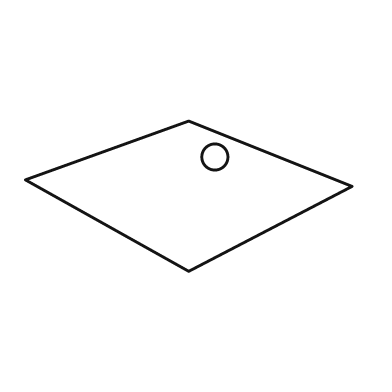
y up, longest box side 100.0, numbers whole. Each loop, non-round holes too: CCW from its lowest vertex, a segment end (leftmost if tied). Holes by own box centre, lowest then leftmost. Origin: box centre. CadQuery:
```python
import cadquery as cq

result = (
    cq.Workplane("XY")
    .moveTo(0.0, -23.0)
    .lineTo(50.0, 3.0)
    .lineTo(0.0, 23.0)
    .lineTo(-50.0, 5.0)
    .close()
    .moveTo(8.0, 12.0)
    .circle(4.0)
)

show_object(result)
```